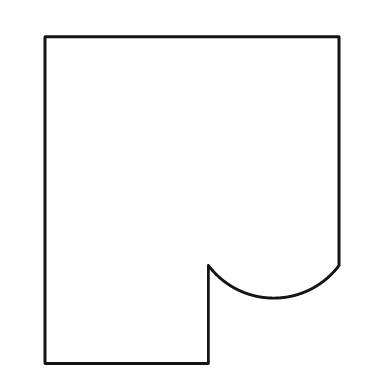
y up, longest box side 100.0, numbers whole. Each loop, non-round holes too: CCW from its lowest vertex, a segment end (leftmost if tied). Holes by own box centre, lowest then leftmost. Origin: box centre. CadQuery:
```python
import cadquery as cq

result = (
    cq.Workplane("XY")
    .moveTo(-45.0, -50.0)
    .lineTo(5.0, -50.0)
    .lineTo(5.0, -20.0)
    .threePointArc((25.0, -30.0), (45.0, -20.0))
    .lineTo(45.0, 50.0)
    .lineTo(-45.0, 50.0)
    .close()
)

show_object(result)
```